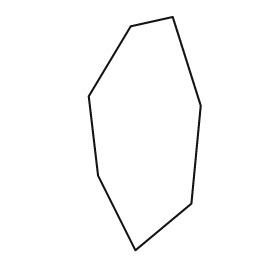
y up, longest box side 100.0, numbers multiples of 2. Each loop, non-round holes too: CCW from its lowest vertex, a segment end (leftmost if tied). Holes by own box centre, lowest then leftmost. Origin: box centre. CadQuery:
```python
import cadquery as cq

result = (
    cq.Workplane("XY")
    .moveTo(-4.0, -50.0)
    .lineTo(20.0, -30.0)
    .lineTo(24.0, 12.0)
    .lineTo(12.0, 50.0)
    .lineTo(-6.0, 46.0)
    .lineTo(-24.0, 16.0)
    .lineTo(-20.0, -18.0)
    .close()
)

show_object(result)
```